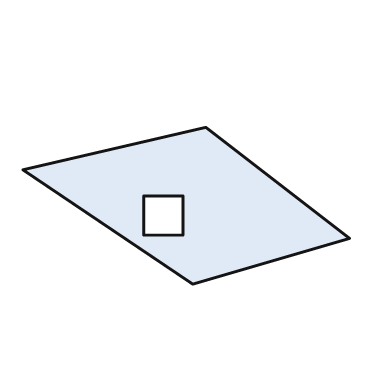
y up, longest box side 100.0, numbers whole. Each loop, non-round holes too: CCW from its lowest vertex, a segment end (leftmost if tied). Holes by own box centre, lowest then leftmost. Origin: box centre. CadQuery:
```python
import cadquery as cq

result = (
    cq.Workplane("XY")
    .moveTo(2.0, -24.0)
    .lineTo(50.0, -10.0)
    .lineTo(6.0, 24.0)
    .lineTo(-50.0, 11.0)
    .close()
    .moveTo(-13.0, -9.0)
    .lineTo(-1.0, -9.0)
    .lineTo(-1.0, 3.0)
    .lineTo(-13.0, 3.0)
    .close()
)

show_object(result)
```